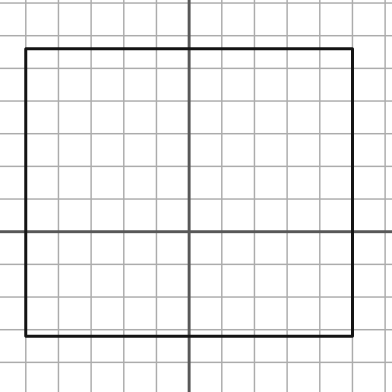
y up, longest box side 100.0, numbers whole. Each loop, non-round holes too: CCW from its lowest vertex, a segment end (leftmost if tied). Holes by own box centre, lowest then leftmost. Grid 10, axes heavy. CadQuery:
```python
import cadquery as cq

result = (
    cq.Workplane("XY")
    .moveTo(-50.0, -32.0)
    .lineTo(50.0, -32.0)
    .lineTo(50.0, 56.0)
    .lineTo(-50.0, 56.0)
    .close()
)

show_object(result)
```